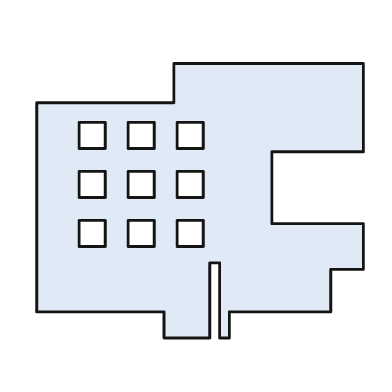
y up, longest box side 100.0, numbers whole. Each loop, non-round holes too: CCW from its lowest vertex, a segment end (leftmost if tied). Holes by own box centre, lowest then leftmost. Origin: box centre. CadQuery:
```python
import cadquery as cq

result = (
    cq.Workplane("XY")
    .moveTo(-11.0, -42.0)
    .lineTo(3.0, -42.0)
    .lineTo(3.0, -19.0)
    .lineTo(6.0, -19.0)
    .lineTo(6.0, -42.0)
    .lineTo(9.0, -42.0)
    .lineTo(9.0, -34.0)
    .lineTo(40.0, -34.0)
    .lineTo(40.0, -21.0)
    .lineTo(50.0, -21.0)
    .lineTo(50.0, -7.0)
    .lineTo(22.0, -7.0)
    .lineTo(22.0, 15.0)
    .lineTo(50.0, 15.0)
    .lineTo(50.0, 42.0)
    .lineTo(-8.0, 42.0)
    .lineTo(-8.0, 30.0)
    .lineTo(-50.0, 30.0)
    .lineTo(-50.0, -34.0)
    .lineTo(-11.0, -34.0)
    .close()
    .moveTo(-37.0, -14.0)
    .lineTo(-29.0, -14.0)
    .lineTo(-29.0, -6.0)
    .lineTo(-37.0, -6.0)
    .close()
    .moveTo(-22.0, -14.0)
    .lineTo(-14.0, -14.0)
    .lineTo(-14.0, -6.0)
    .lineTo(-22.0, -6.0)
    .close()
    .moveTo(-7.0, -14.0)
    .lineTo(1.0, -14.0)
    .lineTo(1.0, -6.0)
    .lineTo(-7.0, -6.0)
    .close()
    .moveTo(-37.0, 1.0)
    .lineTo(-29.0, 1.0)
    .lineTo(-29.0, 9.0)
    .lineTo(-37.0, 9.0)
    .close()
    .moveTo(-22.0, 1.0)
    .lineTo(-14.0, 1.0)
    .lineTo(-14.0, 9.0)
    .lineTo(-22.0, 9.0)
    .close()
    .moveTo(-7.0, 1.0)
    .lineTo(1.0, 1.0)
    .lineTo(1.0, 9.0)
    .lineTo(-7.0, 9.0)
    .close()
    .moveTo(-37.0, 16.0)
    .lineTo(-29.0, 16.0)
    .lineTo(-29.0, 24.0)
    .lineTo(-37.0, 24.0)
    .close()
    .moveTo(-22.0, 16.0)
    .lineTo(-14.0, 16.0)
    .lineTo(-14.0, 24.0)
    .lineTo(-22.0, 24.0)
    .close()
    .moveTo(-7.0, 16.0)
    .lineTo(1.0, 16.0)
    .lineTo(1.0, 24.0)
    .lineTo(-7.0, 24.0)
    .close()
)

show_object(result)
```